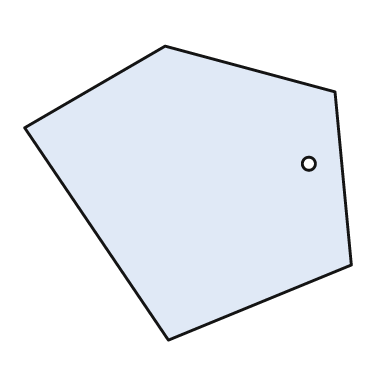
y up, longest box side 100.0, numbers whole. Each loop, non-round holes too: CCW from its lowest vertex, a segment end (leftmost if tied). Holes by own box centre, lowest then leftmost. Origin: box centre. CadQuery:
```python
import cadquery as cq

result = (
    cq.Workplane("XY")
    .moveTo(-6.0, -45.0)
    .lineTo(50.0, -22.0)
    .lineTo(45.0, 31.0)
    .lineTo(-7.0, 45.0)
    .lineTo(-50.0, 20.0)
    .close()
    .moveTo(37.0, 9.0)
    .circle(2.0)
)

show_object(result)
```